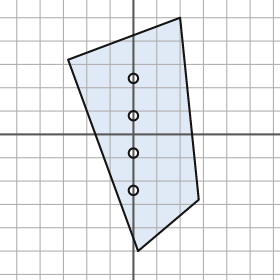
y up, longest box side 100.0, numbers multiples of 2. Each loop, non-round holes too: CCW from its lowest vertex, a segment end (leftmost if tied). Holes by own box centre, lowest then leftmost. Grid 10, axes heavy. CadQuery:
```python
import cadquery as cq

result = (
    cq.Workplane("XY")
    .moveTo(2.0, -50.0)
    .lineTo(28.0, -28.0)
    .lineTo(20.0, 50.0)
    .lineTo(-28.0, 32.0)
    .close()
    .moveTo(0.0, -24.0)
    .circle(2.0)
    .moveTo(0.0, -8.0)
    .circle(2.0)
    .moveTo(0.0, 8.0)
    .circle(2.0)
    .moveTo(0.0, 24.0)
    .circle(2.0)
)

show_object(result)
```